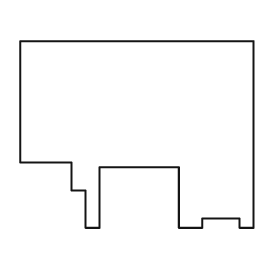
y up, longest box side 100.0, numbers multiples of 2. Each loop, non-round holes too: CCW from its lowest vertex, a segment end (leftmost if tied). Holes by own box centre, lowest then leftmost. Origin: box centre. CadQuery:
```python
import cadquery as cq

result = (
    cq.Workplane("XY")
    .moveTo(-22.0, -40.0)
    .lineTo(-16.0, -40.0)
    .lineTo(-16.0, -14.0)
    .lineTo(18.0, -14.0)
    .lineTo(18.0, -40.0)
    .lineTo(28.0, -40.0)
    .lineTo(28.0, -36.0)
    .lineTo(44.0, -36.0)
    .lineTo(44.0, -40.0)
    .lineTo(50.0, -40.0)
    .lineTo(50.0, 40.0)
    .lineTo(-50.0, 40.0)
    .lineTo(-50.0, -12.0)
    .lineTo(-28.0, -12.0)
    .lineTo(-28.0, -24.0)
    .lineTo(-22.0, -24.0)
    .close()
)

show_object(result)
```